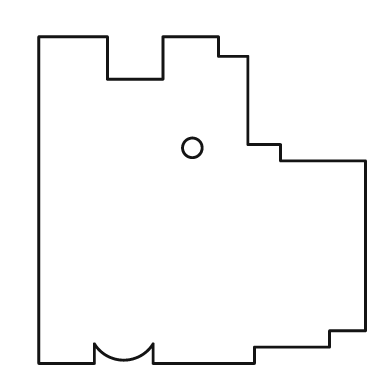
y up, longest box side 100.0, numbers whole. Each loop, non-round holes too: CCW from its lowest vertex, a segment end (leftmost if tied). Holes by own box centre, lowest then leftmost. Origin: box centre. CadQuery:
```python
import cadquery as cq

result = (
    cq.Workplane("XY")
    .moveTo(-50.0, -50.0)
    .lineTo(-33.0, -50.0)
    .lineTo(-33.0, -44.0)
    .threePointArc((-24.0, -49.0), (-15.0, -44.0))
    .lineTo(-15.0, -50.0)
    .lineTo(16.0, -50.0)
    .lineTo(16.0, -45.0)
    .lineTo(39.0, -45.0)
    .lineTo(39.0, -40.0)
    .lineTo(50.0, -40.0)
    .lineTo(50.0, 12.0)
    .lineTo(24.0, 12.0)
    .lineTo(24.0, 17.0)
    .lineTo(14.0, 17.0)
    .lineTo(14.0, 44.0)
    .lineTo(5.0, 44.0)
    .lineTo(5.0, 50.0)
    .lineTo(-12.0, 50.0)
    .lineTo(-12.0, 37.0)
    .lineTo(-29.0, 37.0)
    .lineTo(-29.0, 50.0)
    .lineTo(-50.0, 50.0)
    .close()
    .moveTo(-3.0, 16.0)
    .circle(3.0)
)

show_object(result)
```